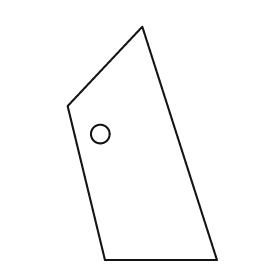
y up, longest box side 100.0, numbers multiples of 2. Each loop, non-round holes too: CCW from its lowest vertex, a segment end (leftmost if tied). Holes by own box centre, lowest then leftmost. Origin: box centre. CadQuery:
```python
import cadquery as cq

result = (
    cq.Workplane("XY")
    .moveTo(-16.0, -50.0)
    .lineTo(32.0, -50.0)
    .lineTo(0.0, 50.0)
    .lineTo(-32.0, 16.0)
    .close()
    .moveTo(-18.0, 4.0)
    .circle(4.0)
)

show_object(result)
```